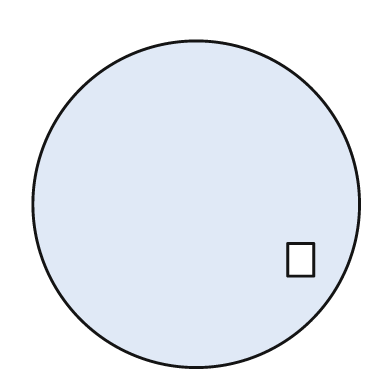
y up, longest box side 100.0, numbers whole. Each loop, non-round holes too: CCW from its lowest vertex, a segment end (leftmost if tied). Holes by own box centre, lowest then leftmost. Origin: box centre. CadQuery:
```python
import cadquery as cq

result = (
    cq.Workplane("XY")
    .moveTo(0.0, 0.0)
    .circle(50.0)
    .moveTo(28.0, -22.0)
    .lineTo(36.0, -22.0)
    .lineTo(36.0, -12.0)
    .lineTo(28.0, -12.0)
    .close()
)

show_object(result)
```